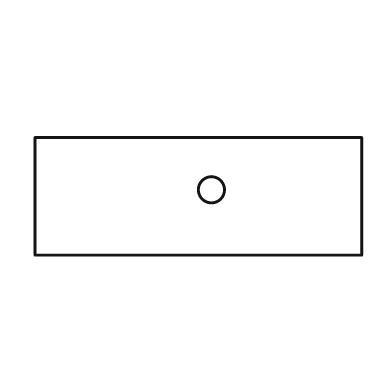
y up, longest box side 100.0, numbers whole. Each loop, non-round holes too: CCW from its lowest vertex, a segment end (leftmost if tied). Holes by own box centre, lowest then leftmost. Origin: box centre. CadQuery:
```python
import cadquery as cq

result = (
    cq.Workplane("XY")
    .moveTo(-50.0, -18.0)
    .lineTo(50.0, -18.0)
    .lineTo(50.0, 18.0)
    .lineTo(-50.0, 18.0)
    .close()
    .moveTo(4.0, 2.0)
    .circle(4.0)
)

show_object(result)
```